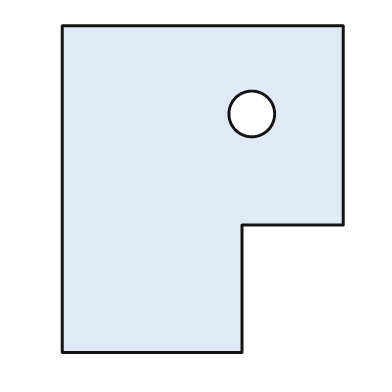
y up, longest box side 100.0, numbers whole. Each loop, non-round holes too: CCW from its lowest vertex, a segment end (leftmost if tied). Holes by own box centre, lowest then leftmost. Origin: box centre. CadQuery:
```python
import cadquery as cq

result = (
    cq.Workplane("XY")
    .moveTo(-43.0, -50.0)
    .lineTo(12.0, -50.0)
    .lineTo(12.0, -11.0)
    .lineTo(43.0, -11.0)
    .lineTo(43.0, 50.0)
    .lineTo(-43.0, 50.0)
    .close()
    .moveTo(15.0, 23.0)
    .circle(7.0)
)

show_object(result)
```